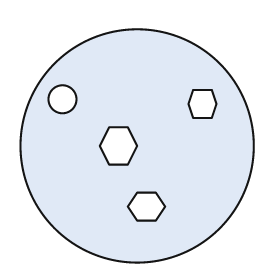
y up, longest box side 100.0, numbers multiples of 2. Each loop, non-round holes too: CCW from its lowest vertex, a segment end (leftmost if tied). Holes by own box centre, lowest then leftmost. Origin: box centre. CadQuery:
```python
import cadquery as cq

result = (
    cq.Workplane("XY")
    .moveTo(0.0, 0.0)
    .circle(50.0)
    .moveTo(0.0, -32.0)
    .lineTo(8.0, -32.0)
    .lineTo(12.0, -26.0)
    .lineTo(8.0, -20.0)
    .lineTo(0.0, -20.0)
    .lineTo(-4.0, -26.0)
    .close()
    .moveTo(-12.0, -8.0)
    .lineTo(-4.0, -8.0)
    .lineTo(0.0, 0.0)
    .lineTo(-4.0, 8.0)
    .lineTo(-12.0, 8.0)
    .lineTo(-16.0, 0.0)
    .close()
    .moveTo(24.0, 12.0)
    .lineTo(32.0, 12.0)
    .lineTo(34.0, 18.0)
    .lineTo(32.0, 24.0)
    .lineTo(24.0, 24.0)
    .lineTo(22.0, 18.0)
    .close()
    .moveTo(-32.0, 20.0)
    .circle(6.0)
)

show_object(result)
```